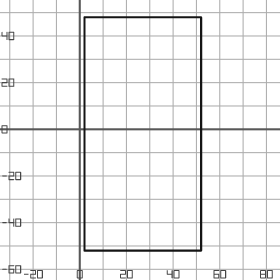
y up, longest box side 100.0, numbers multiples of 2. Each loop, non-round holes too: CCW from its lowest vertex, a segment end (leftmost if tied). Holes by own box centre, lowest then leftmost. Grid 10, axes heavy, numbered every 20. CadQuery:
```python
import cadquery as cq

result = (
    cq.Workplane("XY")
    .moveTo(2.0, -52.0)
    .lineTo(52.0, -52.0)
    .lineTo(52.0, 48.0)
    .lineTo(2.0, 48.0)
    .close()
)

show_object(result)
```